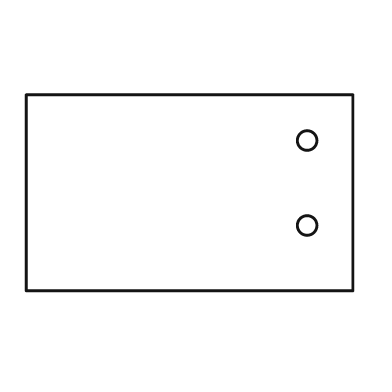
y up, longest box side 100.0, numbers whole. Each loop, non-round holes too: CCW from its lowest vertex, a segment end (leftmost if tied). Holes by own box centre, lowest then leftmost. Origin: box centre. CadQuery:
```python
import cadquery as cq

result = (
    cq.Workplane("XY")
    .moveTo(-50.0, -30.0)
    .lineTo(50.0, -30.0)
    .lineTo(50.0, 30.0)
    .lineTo(-50.0, 30.0)
    .close()
    .moveTo(36.0, -10.0)
    .circle(3.0)
    .moveTo(36.0, 16.0)
    .circle(3.0)
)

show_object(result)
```